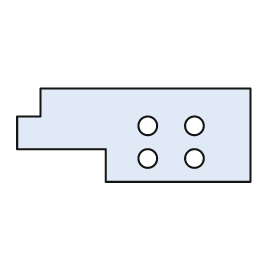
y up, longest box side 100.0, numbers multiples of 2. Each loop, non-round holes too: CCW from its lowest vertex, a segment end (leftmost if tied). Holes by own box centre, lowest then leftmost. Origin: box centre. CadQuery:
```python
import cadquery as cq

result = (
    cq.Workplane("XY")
    .moveTo(-12.0, -20.0)
    .lineTo(50.0, -20.0)
    .lineTo(50.0, 20.0)
    .lineTo(-40.0, 20.0)
    .lineTo(-40.0, 8.0)
    .lineTo(-50.0, 8.0)
    .lineTo(-50.0, -6.0)
    .lineTo(-12.0, -6.0)
    .close()
    .moveTo(6.0, -10.0)
    .circle(4.0)
    .moveTo(26.0, -10.0)
    .circle(4.0)
    .moveTo(6.0, 4.0)
    .circle(4.0)
    .moveTo(26.0, 4.0)
    .circle(4.0)
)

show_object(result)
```